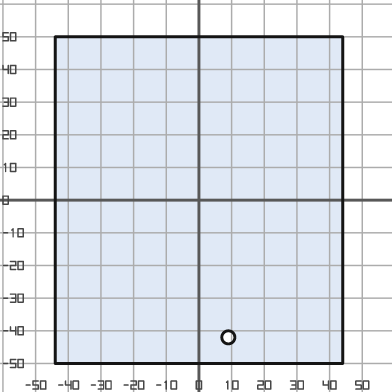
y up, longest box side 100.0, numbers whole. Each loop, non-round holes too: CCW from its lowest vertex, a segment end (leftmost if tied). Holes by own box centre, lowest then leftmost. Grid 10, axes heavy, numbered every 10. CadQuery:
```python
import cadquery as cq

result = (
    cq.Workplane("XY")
    .moveTo(-44.0, -50.0)
    .lineTo(44.0, -50.0)
    .lineTo(44.0, 50.0)
    .lineTo(-44.0, 50.0)
    .close()
    .moveTo(9.0, -42.0)
    .circle(2.0)
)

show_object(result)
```